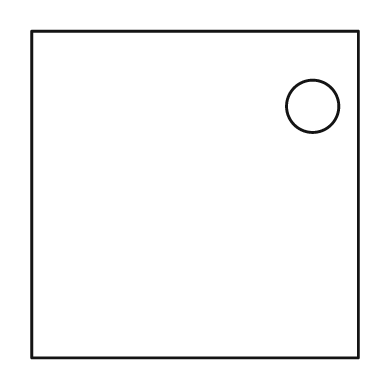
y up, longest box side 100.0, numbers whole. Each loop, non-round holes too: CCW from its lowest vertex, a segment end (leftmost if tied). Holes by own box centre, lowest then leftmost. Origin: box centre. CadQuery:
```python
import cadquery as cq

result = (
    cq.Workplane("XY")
    .moveTo(-50.0, -50.0)
    .lineTo(50.0, -50.0)
    .lineTo(50.0, 50.0)
    .lineTo(-50.0, 50.0)
    .close()
    .moveTo(36.0, 27.0)
    .circle(8.0)
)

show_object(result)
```